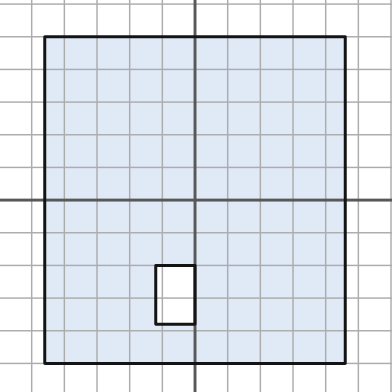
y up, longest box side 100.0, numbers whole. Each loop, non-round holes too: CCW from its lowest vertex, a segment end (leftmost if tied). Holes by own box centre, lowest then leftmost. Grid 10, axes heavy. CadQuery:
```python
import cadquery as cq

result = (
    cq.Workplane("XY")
    .moveTo(-46.0, -50.0)
    .lineTo(46.0, -50.0)
    .lineTo(46.0, 50.0)
    .lineTo(-46.0, 50.0)
    .close()
    .moveTo(-12.0, -38.0)
    .lineTo(0.0, -38.0)
    .lineTo(0.0, -20.0)
    .lineTo(-12.0, -20.0)
    .close()
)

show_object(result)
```